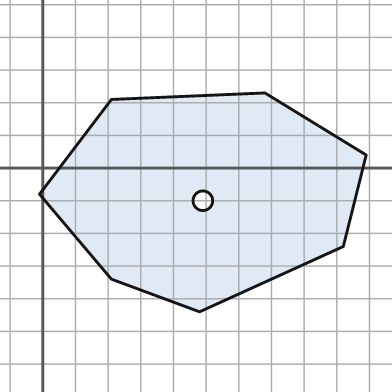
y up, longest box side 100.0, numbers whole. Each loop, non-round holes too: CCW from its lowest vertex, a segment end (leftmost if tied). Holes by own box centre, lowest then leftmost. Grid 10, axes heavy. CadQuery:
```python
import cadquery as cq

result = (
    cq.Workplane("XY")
    .moveTo(48.0, -44.0)
    .lineTo(92.0, -24.0)
    .lineTo(99.0, 4.0)
    .lineTo(68.0, 23.0)
    .lineTo(21.0, 21.0)
    .lineTo(-1.0, -8.0)
    .lineTo(21.0, -34.0)
    .close()
    .moveTo(49.0, -10.0)
    .circle(3.0)
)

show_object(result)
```